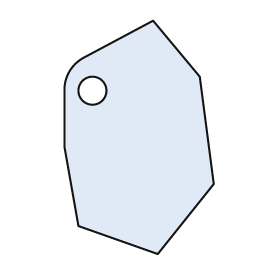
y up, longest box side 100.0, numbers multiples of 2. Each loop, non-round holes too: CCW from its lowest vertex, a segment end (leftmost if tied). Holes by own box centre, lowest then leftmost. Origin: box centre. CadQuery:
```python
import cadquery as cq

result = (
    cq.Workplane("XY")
    .moveTo(8.0, -50.0)
    .lineTo(32.0, -20.0)
    .lineTo(26.0, 26.0)
    .lineTo(6.0, 50.0)
    .lineTo(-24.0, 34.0)
    .threePointArc((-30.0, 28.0), (-32.0, 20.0))
    .lineTo(-32.0, -4.0)
    .lineTo(-26.0, -38.0)
    .close()
    .moveTo(-20.0, 20.0)
    .circle(6.0)
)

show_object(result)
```